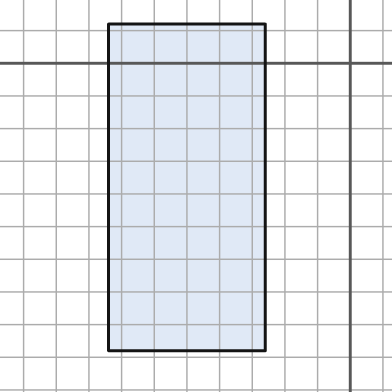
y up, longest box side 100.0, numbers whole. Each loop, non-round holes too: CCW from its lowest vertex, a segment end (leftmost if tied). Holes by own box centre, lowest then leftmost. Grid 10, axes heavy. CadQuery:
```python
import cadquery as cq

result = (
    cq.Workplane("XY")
    .moveTo(-74.0, -88.0)
    .lineTo(-26.0, -88.0)
    .lineTo(-26.0, 12.0)
    .lineTo(-74.0, 12.0)
    .close()
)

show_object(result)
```